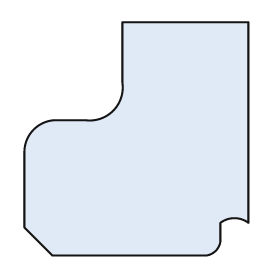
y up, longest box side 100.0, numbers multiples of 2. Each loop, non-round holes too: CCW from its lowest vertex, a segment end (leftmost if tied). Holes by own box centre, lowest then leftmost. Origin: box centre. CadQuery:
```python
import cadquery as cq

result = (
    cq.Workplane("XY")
    .moveTo(-36.0, -50.0)
    .lineTo(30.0, -50.0)
    .threePointArc((34.0, -48.0), (36.0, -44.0))
    .lineTo(36.0, -36.0)
    .threePointArc((42.0, -34.0), (48.0, -36.0))
    .lineTo(48.0, 50.0)
    .lineTo(-6.0, 50.0)
    .lineTo(-6.0, 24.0)
    .threePointArc((-10.0, 12.0), (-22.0, 8.0))
    .lineTo(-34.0, 8.0)
    .threePointArc((-44.0, 4.0), (-48.0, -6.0))
    .lineTo(-48.0, -38.0)
    .close()
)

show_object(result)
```